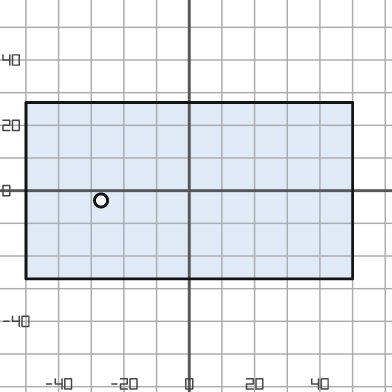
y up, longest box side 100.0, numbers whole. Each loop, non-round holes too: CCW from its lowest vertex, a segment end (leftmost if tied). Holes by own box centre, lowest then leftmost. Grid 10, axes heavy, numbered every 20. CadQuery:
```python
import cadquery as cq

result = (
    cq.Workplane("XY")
    .moveTo(-50.0, -27.0)
    .lineTo(50.0, -27.0)
    .lineTo(50.0, 27.0)
    .lineTo(-50.0, 27.0)
    .close()
    .moveTo(-27.0, -3.0)
    .circle(2.0)
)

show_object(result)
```